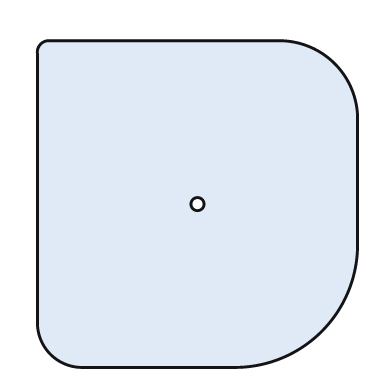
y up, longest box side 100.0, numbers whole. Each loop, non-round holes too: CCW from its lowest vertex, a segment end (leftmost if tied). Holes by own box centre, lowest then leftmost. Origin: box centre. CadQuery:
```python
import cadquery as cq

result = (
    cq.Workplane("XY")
    .moveTo(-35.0, -50.0)
    .lineTo(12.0, -50.0)
    .threePointArc((38.0, -39.0), (49.0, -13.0))
    .lineTo(49.0, 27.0)
    .threePointArc((42.0, 43.0), (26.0, 50.0))
    .lineTo(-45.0, 50.0)
    .threePointArc((-48.0, 49.0), (-49.0, 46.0))
    .lineTo(-49.0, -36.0)
    .threePointArc((-45.0, -46.0), (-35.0, -50.0))
    .close()
    .moveTo(0.0, 0.0)
    .circle(2.0)
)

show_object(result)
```